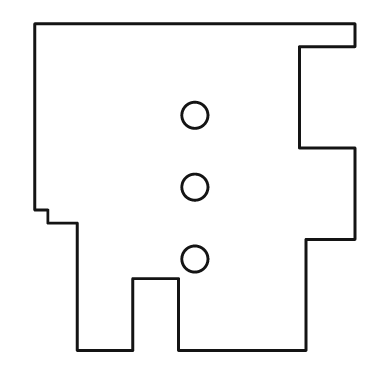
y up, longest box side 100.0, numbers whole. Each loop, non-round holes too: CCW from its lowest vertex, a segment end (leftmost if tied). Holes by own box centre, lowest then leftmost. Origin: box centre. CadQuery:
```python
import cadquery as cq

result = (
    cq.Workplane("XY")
    .moveTo(-36.0, -50.0)
    .lineTo(-19.0, -50.0)
    .lineTo(-19.0, -28.0)
    .lineTo(-5.0, -28.0)
    .lineTo(-5.0, -50.0)
    .lineTo(34.0, -50.0)
    .lineTo(34.0, -16.0)
    .lineTo(49.0, -16.0)
    .lineTo(49.0, 12.0)
    .lineTo(32.0, 12.0)
    .lineTo(32.0, 43.0)
    .lineTo(49.0, 43.0)
    .lineTo(49.0, 50.0)
    .lineTo(-49.0, 50.0)
    .lineTo(-49.0, -7.0)
    .lineTo(-45.0, -7.0)
    .lineTo(-45.0, -11.0)
    .lineTo(-36.0, -11.0)
    .close()
    .moveTo(0.0, -22.0)
    .circle(4.0)
    .moveTo(0.0, 0.0)
    .circle(4.0)
    .moveTo(0.0, 22.0)
    .circle(4.0)
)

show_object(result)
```